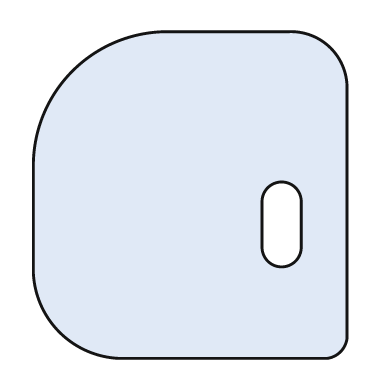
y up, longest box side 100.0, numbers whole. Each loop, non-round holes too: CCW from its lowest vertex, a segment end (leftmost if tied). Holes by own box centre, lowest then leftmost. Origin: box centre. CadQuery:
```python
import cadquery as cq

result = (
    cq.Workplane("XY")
    .moveTo(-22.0, -50.0)
    .lineTo(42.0, -50.0)
    .threePointArc((46.0, -48.0), (48.0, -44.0))
    .lineTo(48.0, 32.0)
    .threePointArc((43.0, 45.0), (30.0, 50.0))
    .lineTo(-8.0, 50.0)
    .threePointArc((-36.0, 38.0), (-48.0, 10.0))
    .lineTo(-48.0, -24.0)
    .threePointArc((-40.0, -42.0), (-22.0, -50.0))
    .close()
    .moveTo(22.0, -16.0)
    .threePointArc((28.0, -22.0), (34.0, -16.0))
    .lineTo(34.0, -2.0)
    .threePointArc((28.0, 4.0), (22.0, -2.0))
    .close()
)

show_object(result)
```